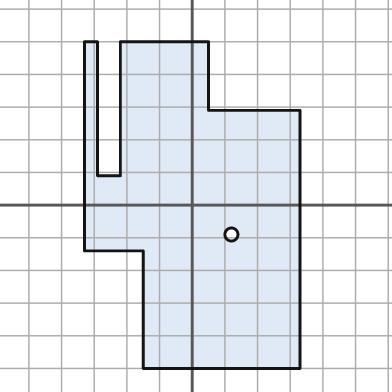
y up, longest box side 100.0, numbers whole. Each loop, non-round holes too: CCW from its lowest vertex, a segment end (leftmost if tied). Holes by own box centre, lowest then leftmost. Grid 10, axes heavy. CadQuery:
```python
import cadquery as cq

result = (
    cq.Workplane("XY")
    .moveTo(-15.0, -50.0)
    .lineTo(33.0, -50.0)
    .lineTo(33.0, 29.0)
    .lineTo(5.0, 29.0)
    .lineTo(5.0, 50.0)
    .lineTo(-22.0, 50.0)
    .lineTo(-22.0, 9.0)
    .lineTo(-29.0, 9.0)
    .lineTo(-29.0, 50.0)
    .lineTo(-33.0, 50.0)
    .lineTo(-33.0, -14.0)
    .lineTo(-15.0, -14.0)
    .close()
    .moveTo(12.0, -9.0)
    .circle(2.0)
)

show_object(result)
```